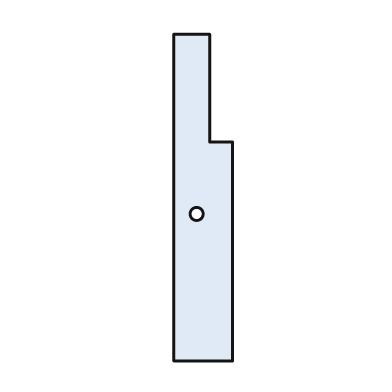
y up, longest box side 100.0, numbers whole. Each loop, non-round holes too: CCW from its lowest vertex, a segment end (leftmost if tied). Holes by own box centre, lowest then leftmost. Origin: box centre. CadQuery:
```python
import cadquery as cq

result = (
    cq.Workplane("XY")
    .moveTo(-9.0, -50.0)
    .lineTo(9.0, -50.0)
    .lineTo(9.0, 17.0)
    .lineTo(2.0, 17.0)
    .lineTo(2.0, 50.0)
    .lineTo(-9.0, 50.0)
    .close()
    .moveTo(-2.0, -5.0)
    .circle(2.0)
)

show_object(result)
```